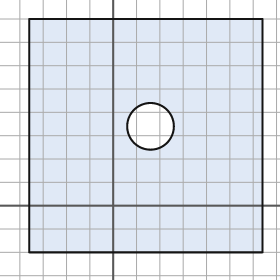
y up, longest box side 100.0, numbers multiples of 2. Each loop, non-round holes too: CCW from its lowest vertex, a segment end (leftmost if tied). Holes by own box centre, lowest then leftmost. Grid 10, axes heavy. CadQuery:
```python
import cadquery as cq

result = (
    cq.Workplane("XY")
    .moveTo(-36.0, -20.0)
    .lineTo(64.0, -20.0)
    .lineTo(64.0, 80.0)
    .lineTo(-36.0, 80.0)
    .close()
    .moveTo(16.0, 34.0)
    .circle(10.0)
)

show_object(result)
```